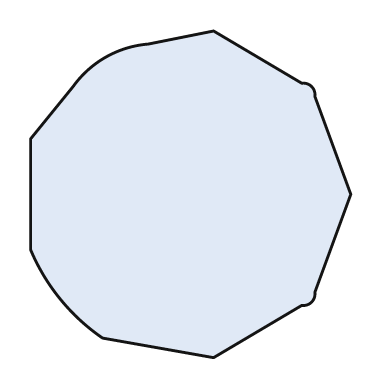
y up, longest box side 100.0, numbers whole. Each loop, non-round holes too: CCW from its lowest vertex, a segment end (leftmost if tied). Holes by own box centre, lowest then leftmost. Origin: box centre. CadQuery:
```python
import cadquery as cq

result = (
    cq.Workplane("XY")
    .moveTo(7.0, -50.0)
    .lineTo(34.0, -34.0)
    .threePointArc((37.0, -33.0), (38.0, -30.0))
    .lineTo(49.0, 0.0)
    .lineTo(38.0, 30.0)
    .threePointArc((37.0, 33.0), (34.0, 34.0))
    .lineTo(7.0, 50.0)
    .lineTo(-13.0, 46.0)
    .threePointArc((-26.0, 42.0), (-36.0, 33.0))
    .lineTo(-49.0, 17.0)
    .lineTo(-49.0, -17.0)
    .threePointArc((-40.0, -32.0), (-27.0, -44.0))
    .close()
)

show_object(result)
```